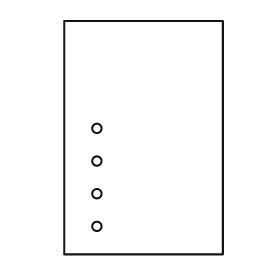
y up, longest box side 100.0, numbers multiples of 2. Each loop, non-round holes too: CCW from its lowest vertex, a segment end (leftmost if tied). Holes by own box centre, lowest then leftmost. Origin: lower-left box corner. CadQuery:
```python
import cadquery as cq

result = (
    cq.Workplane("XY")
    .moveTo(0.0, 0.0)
    .lineTo(68.0, 0.0)
    .lineTo(68.0, 100.0)
    .lineTo(0.0, 100.0)
    .close()
    .moveTo(14.0, 12.0)
    .circle(2.0)
    .moveTo(14.0, 26.0)
    .circle(2.0)
    .moveTo(14.0, 40.0)
    .circle(2.0)
    .moveTo(14.0, 54.0)
    .circle(2.0)
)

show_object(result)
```